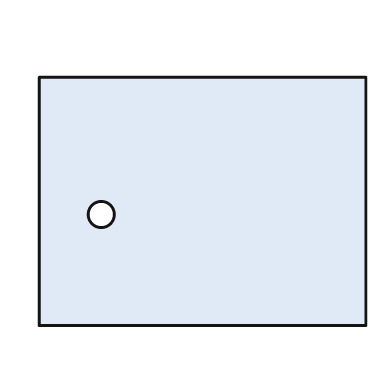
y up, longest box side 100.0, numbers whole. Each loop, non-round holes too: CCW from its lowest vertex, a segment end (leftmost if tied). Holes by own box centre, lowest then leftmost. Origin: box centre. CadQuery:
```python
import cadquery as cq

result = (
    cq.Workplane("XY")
    .moveTo(-50.0, -38.0)
    .lineTo(50.0, -38.0)
    .lineTo(50.0, 38.0)
    .lineTo(-50.0, 38.0)
    .close()
    .moveTo(-31.0, -4.0)
    .circle(4.0)
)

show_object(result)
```